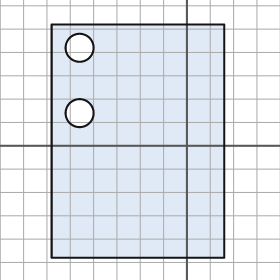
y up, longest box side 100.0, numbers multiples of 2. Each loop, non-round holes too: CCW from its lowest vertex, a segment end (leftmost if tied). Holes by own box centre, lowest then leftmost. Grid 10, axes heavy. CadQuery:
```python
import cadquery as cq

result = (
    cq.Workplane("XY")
    .moveTo(-58.0, -48.0)
    .lineTo(16.0, -48.0)
    .lineTo(16.0, 52.0)
    .lineTo(-58.0, 52.0)
    .close()
    .moveTo(-46.0, 14.0)
    .circle(6.0)
    .moveTo(-46.0, 42.0)
    .circle(6.0)
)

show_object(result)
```